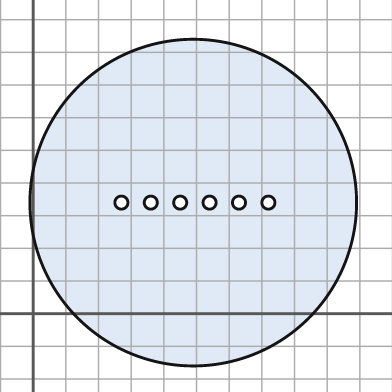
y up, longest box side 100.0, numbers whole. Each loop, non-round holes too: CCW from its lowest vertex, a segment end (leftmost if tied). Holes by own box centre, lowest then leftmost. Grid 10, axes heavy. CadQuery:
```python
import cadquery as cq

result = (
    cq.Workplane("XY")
    .moveTo(49.0, 34.0)
    .circle(50.0)
    .moveTo(27.0, 34.0)
    .circle(2.0)
    .moveTo(36.0, 34.0)
    .circle(2.0)
    .moveTo(45.0, 34.0)
    .circle(2.0)
    .moveTo(54.0, 34.0)
    .circle(2.0)
    .moveTo(63.0, 34.0)
    .circle(2.0)
    .moveTo(72.0, 34.0)
    .circle(2.0)
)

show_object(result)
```